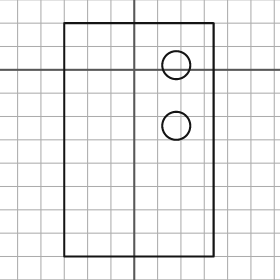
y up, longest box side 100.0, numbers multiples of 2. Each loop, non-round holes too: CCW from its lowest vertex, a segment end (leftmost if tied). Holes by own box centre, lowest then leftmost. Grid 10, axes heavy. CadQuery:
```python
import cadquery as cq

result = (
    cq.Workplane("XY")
    .moveTo(-30.0, -80.0)
    .lineTo(34.0, -80.0)
    .lineTo(34.0, 20.0)
    .lineTo(-30.0, 20.0)
    .close()
    .moveTo(18.0, -24.0)
    .circle(6.0)
    .moveTo(18.0, 2.0)
    .circle(6.0)
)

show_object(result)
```